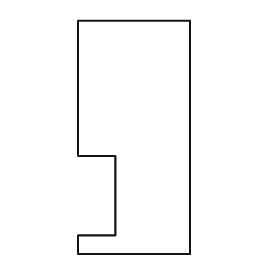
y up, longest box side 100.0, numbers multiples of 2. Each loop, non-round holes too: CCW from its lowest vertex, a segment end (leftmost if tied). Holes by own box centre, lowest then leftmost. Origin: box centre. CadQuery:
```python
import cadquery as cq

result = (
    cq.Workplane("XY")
    .moveTo(-24.0, -50.0)
    .lineTo(24.0, -50.0)
    .lineTo(24.0, 50.0)
    .lineTo(-24.0, 50.0)
    .lineTo(-24.0, -8.0)
    .lineTo(-8.0, -8.0)
    .lineTo(-8.0, -42.0)
    .lineTo(-24.0, -42.0)
    .close()
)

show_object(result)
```